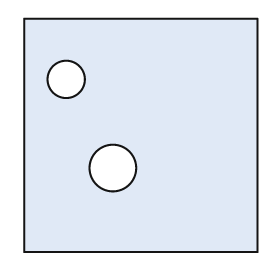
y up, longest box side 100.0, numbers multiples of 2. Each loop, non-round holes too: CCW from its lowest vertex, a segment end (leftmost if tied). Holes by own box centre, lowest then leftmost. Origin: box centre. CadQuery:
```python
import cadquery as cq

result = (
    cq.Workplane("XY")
    .moveTo(-50.0, -50.0)
    .lineTo(50.0, -50.0)
    .lineTo(50.0, 50.0)
    .lineTo(-50.0, 50.0)
    .close()
    .moveTo(-12.0, -14.0)
    .circle(10.0)
    .moveTo(-32.0, 24.0)
    .circle(8.0)
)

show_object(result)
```